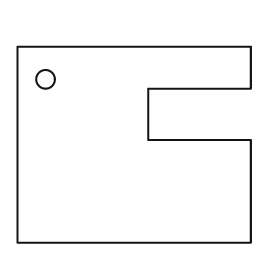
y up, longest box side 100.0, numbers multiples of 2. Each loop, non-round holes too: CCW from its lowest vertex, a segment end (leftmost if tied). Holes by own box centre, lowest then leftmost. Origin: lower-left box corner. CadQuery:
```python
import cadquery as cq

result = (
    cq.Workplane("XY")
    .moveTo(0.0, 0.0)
    .lineTo(100.0, 0.0)
    .lineTo(100.0, 44.0)
    .lineTo(56.0, 44.0)
    .lineTo(56.0, 66.0)
    .lineTo(100.0, 66.0)
    .lineTo(100.0, 84.0)
    .lineTo(0.0, 84.0)
    .close()
    .moveTo(12.0, 70.0)
    .circle(4.0)
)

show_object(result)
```